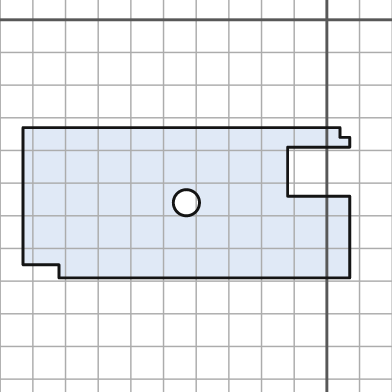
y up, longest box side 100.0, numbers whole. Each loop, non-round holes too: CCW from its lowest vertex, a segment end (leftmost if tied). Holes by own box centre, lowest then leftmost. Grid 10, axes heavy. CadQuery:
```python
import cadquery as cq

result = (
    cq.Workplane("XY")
    .moveTo(-82.0, -79.0)
    .lineTo(7.0, -79.0)
    .lineTo(7.0, -54.0)
    .lineTo(-12.0, -54.0)
    .lineTo(-12.0, -39.0)
    .lineTo(7.0, -39.0)
    .lineTo(7.0, -36.0)
    .lineTo(4.0, -36.0)
    .lineTo(4.0, -33.0)
    .lineTo(-93.0, -33.0)
    .lineTo(-93.0, -75.0)
    .lineTo(-82.0, -75.0)
    .close()
    .moveTo(-43.0, -56.0)
    .circle(4.0)
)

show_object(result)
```